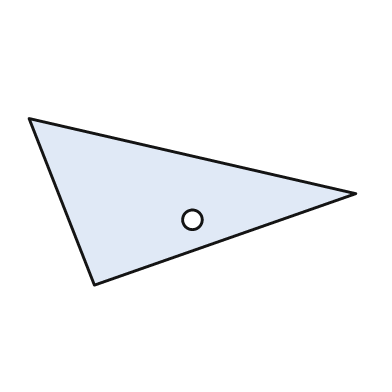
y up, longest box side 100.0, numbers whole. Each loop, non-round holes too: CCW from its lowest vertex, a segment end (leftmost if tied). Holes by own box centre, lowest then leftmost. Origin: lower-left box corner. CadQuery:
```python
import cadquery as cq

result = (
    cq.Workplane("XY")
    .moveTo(20.0, 0.0)
    .lineTo(100.0, 28.0)
    .lineTo(0.0, 51.0)
    .close()
    .moveTo(50.0, 20.0)
    .circle(3.0)
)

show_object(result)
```